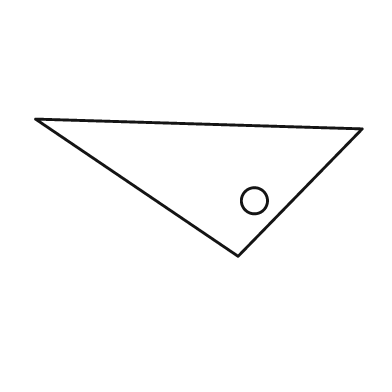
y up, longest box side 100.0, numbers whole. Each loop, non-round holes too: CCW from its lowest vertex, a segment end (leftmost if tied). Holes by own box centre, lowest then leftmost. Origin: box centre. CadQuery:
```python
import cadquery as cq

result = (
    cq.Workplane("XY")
    .moveTo(12.0, -21.0)
    .lineTo(50.0, 18.0)
    .lineTo(-50.0, 21.0)
    .close()
    .moveTo(17.0, -4.0)
    .circle(4.0)
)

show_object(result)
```